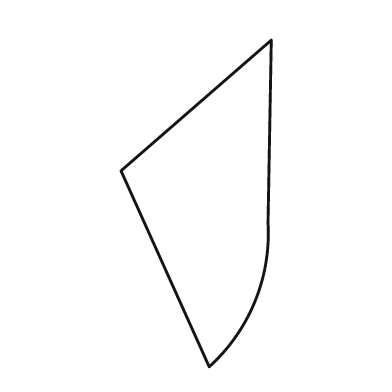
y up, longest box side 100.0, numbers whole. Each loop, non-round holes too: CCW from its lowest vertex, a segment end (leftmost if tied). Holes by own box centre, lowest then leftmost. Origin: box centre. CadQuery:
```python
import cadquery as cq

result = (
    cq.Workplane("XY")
    .moveTo(4.0, -50.0)
    .threePointArc((18.0, -30.0), (22.0, -6.0))
    .lineTo(23.0, 50.0)
    .lineTo(-23.0, 10.0)
    .close()
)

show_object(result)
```